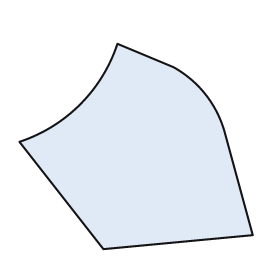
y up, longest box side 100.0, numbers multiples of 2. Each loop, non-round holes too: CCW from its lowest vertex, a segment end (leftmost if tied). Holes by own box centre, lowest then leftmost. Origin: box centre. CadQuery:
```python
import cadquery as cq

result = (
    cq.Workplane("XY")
    .moveTo(-14.0, -44.0)
    .lineTo(50.0, -38.0)
    .lineTo(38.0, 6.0)
    .threePointArc((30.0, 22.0), (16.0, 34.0))
    .lineTo(-8.0, 44.0)
    .threePointArc((-24.0, 18.0), (-50.0, 2.0))
    .close()
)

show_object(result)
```